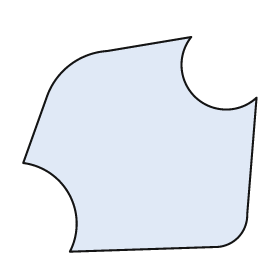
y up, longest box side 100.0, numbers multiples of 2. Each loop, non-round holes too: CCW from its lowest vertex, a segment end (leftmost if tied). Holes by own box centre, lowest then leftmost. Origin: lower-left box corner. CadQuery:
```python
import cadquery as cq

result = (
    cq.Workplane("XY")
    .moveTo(20.0, 0.0)
    .lineTo(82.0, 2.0)
    .threePointArc((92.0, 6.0), (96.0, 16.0))
    .lineTo(100.0, 66.0)
    .threePointArc((74.0, 66.0), (72.0, 92.0))
    .lineTo(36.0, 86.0)
    .threePointArc((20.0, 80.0), (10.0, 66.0))
    .lineTo(0.0, 38.0)
    .threePointArc((20.0, 24.0), (20.0, 0.0))
    .close()
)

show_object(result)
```